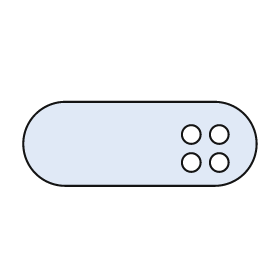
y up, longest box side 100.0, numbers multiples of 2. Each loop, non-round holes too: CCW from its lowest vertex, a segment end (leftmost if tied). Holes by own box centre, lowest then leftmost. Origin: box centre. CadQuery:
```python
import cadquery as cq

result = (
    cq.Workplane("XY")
    .moveTo(-32.0, -18.0)
    .lineTo(32.0, -18.0)
    .threePointArc((50.0, 0.0), (32.0, 18.0))
    .lineTo(-32.0, 18.0)
    .threePointArc((-50.0, 0.0), (-32.0, -18.0))
    .close()
    .moveTo(22.0, -8.0)
    .circle(4.0)
    .moveTo(34.0, -8.0)
    .circle(4.0)
    .moveTo(22.0, 4.0)
    .circle(4.0)
    .moveTo(34.0, 4.0)
    .circle(4.0)
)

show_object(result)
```